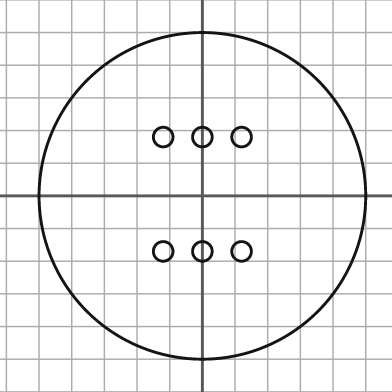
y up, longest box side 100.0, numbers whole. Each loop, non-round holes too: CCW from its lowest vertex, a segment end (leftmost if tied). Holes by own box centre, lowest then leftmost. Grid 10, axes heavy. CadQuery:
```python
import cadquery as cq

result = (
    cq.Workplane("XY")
    .moveTo(0.0, 0.0)
    .circle(50.0)
    .moveTo(-12.0, -17.0)
    .circle(3.0)
    .moveTo(0.0, -17.0)
    .circle(3.0)
    .moveTo(12.0, -17.0)
    .circle(3.0)
    .moveTo(-12.0, 18.0)
    .circle(3.0)
    .moveTo(0.0, 18.0)
    .circle(3.0)
    .moveTo(12.0, 18.0)
    .circle(3.0)
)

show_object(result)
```